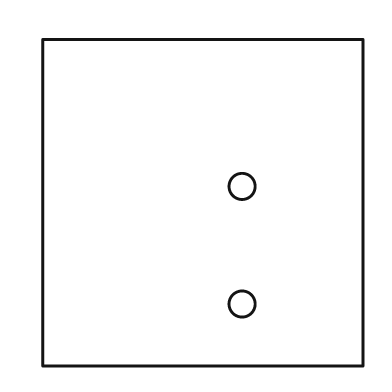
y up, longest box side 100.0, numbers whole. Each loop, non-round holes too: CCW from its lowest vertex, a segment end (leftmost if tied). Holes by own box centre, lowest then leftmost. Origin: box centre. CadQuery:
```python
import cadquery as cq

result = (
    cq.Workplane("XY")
    .moveTo(-49.0, -50.0)
    .lineTo(49.0, -50.0)
    .lineTo(49.0, 50.0)
    .lineTo(-49.0, 50.0)
    .close()
    .moveTo(12.0, -31.0)
    .circle(4.0)
    .moveTo(12.0, 5.0)
    .circle(4.0)
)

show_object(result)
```